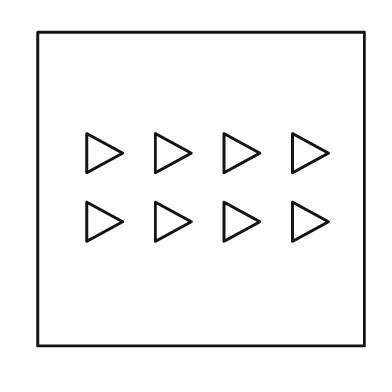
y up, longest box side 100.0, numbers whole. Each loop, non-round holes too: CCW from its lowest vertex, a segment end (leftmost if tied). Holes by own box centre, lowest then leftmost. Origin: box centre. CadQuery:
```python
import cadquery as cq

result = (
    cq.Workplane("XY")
    .moveTo(-50.0, -48.0)
    .lineTo(50.0, -48.0)
    .lineTo(50.0, 48.0)
    .lineTo(-50.0, 48.0)
    .close()
    .moveTo(-35.0, -16.0)
    .lineTo(-24.0, -10.0)
    .lineTo(-35.0, -4.0)
    .close()
    .moveTo(-14.0, -16.0)
    .lineTo(-3.0, -10.0)
    .lineTo(-14.0, -4.0)
    .close()
    .moveTo(7.0, -16.0)
    .lineTo(18.0, -10.0)
    .lineTo(7.0, -4.0)
    .close()
    .moveTo(28.0, -16.0)
    .lineTo(39.0, -10.0)
    .lineTo(28.0, -4.0)
    .close()
    .moveTo(-35.0, 5.0)
    .lineTo(-24.0, 11.0)
    .lineTo(-35.0, 17.0)
    .close()
    .moveTo(-14.0, 5.0)
    .lineTo(-3.0, 11.0)
    .lineTo(-14.0, 17.0)
    .close()
    .moveTo(7.0, 5.0)
    .lineTo(18.0, 11.0)
    .lineTo(7.0, 17.0)
    .close()
    .moveTo(28.0, 5.0)
    .lineTo(39.0, 11.0)
    .lineTo(28.0, 17.0)
    .close()
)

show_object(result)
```